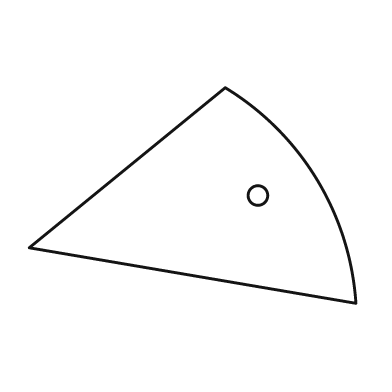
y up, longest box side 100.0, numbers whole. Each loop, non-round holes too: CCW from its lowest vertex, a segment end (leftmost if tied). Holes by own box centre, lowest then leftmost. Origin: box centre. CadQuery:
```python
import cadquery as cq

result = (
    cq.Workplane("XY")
    .moveTo(50.0, -33.0)
    .threePointArc((38.0, 5.0), (10.0, 33.0))
    .lineTo(-50.0, -16.0)
    .close()
    .moveTo(20.0, 0.0)
    .circle(3.0)
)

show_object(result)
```